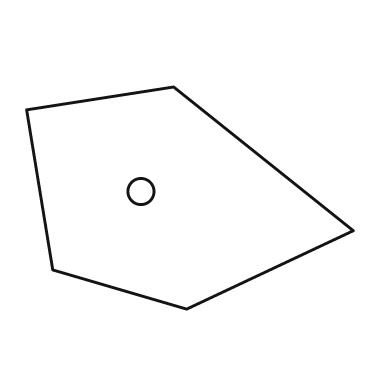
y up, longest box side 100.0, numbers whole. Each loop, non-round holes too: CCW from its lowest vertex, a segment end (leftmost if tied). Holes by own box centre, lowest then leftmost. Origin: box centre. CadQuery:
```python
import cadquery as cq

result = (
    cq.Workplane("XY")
    .moveTo(-1.0, -34.0)
    .lineTo(50.0, -10.0)
    .lineTo(-5.0, 34.0)
    .lineTo(-50.0, 27.0)
    .lineTo(-42.0, -22.0)
    .close()
    .moveTo(-15.0, 2.0)
    .circle(4.0)
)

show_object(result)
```